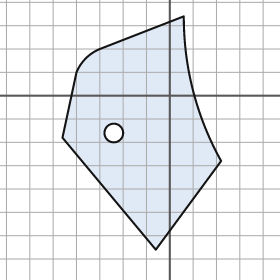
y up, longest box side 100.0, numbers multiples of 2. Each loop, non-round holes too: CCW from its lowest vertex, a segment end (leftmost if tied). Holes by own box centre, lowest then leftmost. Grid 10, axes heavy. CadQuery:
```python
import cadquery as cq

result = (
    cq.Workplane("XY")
    .moveTo(-6.0, -66.0)
    .lineTo(22.0, -28.0)
    .threePointArc((10.0, 2.0), (6.0, 34.0))
    .lineTo(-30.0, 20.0)
    .threePointArc((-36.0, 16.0), (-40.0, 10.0))
    .lineTo(-46.0, -18.0)
    .close()
    .moveTo(-24.0, -16.0)
    .circle(4.0)
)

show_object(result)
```